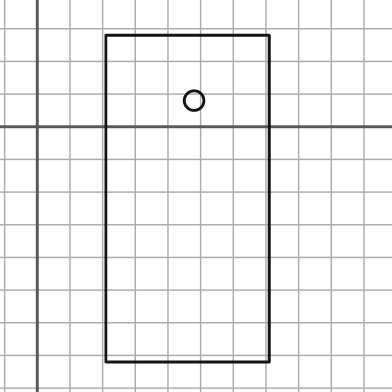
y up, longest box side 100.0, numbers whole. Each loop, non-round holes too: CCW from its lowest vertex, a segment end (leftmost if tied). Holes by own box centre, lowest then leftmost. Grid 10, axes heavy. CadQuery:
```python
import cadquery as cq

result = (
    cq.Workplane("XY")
    .moveTo(21.0, -72.0)
    .lineTo(71.0, -72.0)
    .lineTo(71.0, 28.0)
    .lineTo(21.0, 28.0)
    .close()
    .moveTo(48.0, 8.0)
    .circle(3.0)
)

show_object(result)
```